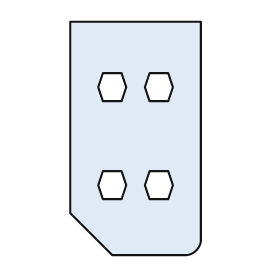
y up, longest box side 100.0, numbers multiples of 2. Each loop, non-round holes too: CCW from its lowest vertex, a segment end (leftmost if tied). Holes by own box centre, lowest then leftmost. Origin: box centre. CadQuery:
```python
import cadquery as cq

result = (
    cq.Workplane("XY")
    .moveTo(-10.0, -50.0)
    .lineTo(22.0, -50.0)
    .threePointArc((26.0, -48.0), (28.0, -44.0))
    .lineTo(28.0, 50.0)
    .lineTo(-28.0, 50.0)
    .lineTo(-28.0, -32.0)
    .close()
    .moveTo(-14.0, -26.0)
    .lineTo(-6.0, -26.0)
    .lineTo(-4.0, -20.0)
    .lineTo(-6.0, -14.0)
    .lineTo(-14.0, -14.0)
    .lineTo(-16.0, -20.0)
    .close()
    .moveTo(6.0, -26.0)
    .lineTo(14.0, -26.0)
    .lineTo(16.0, -20.0)
    .lineTo(14.0, -14.0)
    .lineTo(6.0, -14.0)
    .lineTo(4.0, -20.0)
    .close()
    .moveTo(-14.0, 16.0)
    .lineTo(-6.0, 16.0)
    .lineTo(-4.0, 22.0)
    .lineTo(-6.0, 28.0)
    .lineTo(-14.0, 28.0)
    .lineTo(-16.0, 22.0)
    .close()
    .moveTo(6.0, 16.0)
    .lineTo(14.0, 16.0)
    .lineTo(16.0, 22.0)
    .lineTo(14.0, 28.0)
    .lineTo(6.0, 28.0)
    .lineTo(4.0, 22.0)
    .close()
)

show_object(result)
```